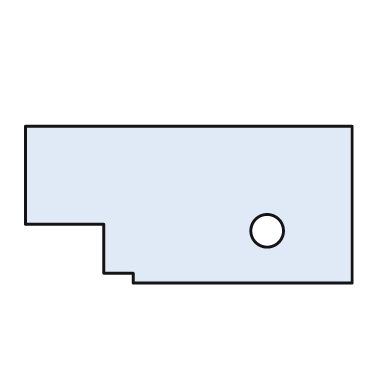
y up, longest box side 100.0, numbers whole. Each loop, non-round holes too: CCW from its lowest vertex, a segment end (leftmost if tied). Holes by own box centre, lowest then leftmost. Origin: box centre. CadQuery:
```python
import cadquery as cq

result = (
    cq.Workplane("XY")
    .moveTo(-17.0, -24.0)
    .lineTo(50.0, -24.0)
    .lineTo(50.0, 24.0)
    .lineTo(-50.0, 24.0)
    .lineTo(-50.0, -6.0)
    .lineTo(-26.0, -6.0)
    .lineTo(-26.0, -21.0)
    .lineTo(-17.0, -21.0)
    .close()
    .moveTo(24.0, -8.0)
    .circle(5.0)
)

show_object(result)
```